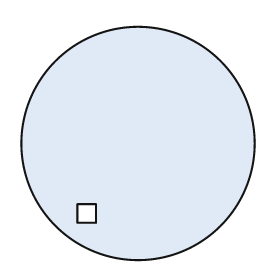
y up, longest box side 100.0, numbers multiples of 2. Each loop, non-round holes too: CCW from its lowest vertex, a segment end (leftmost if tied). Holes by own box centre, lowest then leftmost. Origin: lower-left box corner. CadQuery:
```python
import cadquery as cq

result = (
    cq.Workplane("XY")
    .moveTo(50.0, 50.0)
    .circle(50.0)
    .moveTo(24.0, 16.0)
    .lineTo(32.0, 16.0)
    .lineTo(32.0, 24.0)
    .lineTo(24.0, 24.0)
    .close()
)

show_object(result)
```